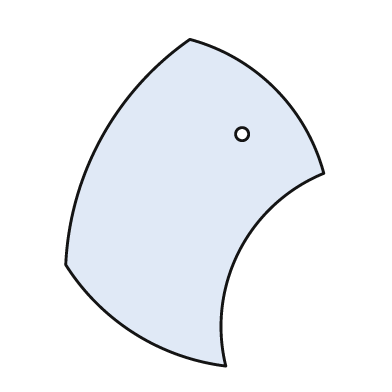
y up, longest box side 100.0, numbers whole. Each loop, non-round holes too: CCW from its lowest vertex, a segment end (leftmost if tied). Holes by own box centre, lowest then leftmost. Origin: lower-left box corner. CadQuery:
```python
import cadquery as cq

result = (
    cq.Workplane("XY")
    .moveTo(49.0, 0.0)
    .threePointArc((53.0, 35.0), (79.0, 59.0))
    .threePointArc((64.0, 85.0), (38.0, 100.0))
    .threePointArc((11.0, 70.0), (0.0, 31.0))
    .threePointArc((21.0, 10.0), (49.0, 0.0))
    .close()
    .moveTo(54.0, 71.0)
    .circle(2.0)
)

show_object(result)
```